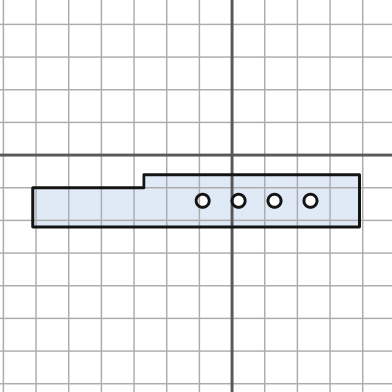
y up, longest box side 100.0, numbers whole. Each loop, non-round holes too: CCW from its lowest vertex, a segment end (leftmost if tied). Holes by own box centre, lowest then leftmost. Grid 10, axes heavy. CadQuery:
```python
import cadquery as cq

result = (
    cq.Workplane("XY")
    .moveTo(-61.0, -22.0)
    .lineTo(39.0, -22.0)
    .lineTo(39.0, -6.0)
    .lineTo(-27.0, -6.0)
    .lineTo(-27.0, -10.0)
    .lineTo(-61.0, -10.0)
    .close()
    .moveTo(-9.0, -14.0)
    .circle(2.0)
    .moveTo(2.0, -14.0)
    .circle(2.0)
    .moveTo(13.0, -14.0)
    .circle(2.0)
    .moveTo(24.0, -14.0)
    .circle(2.0)
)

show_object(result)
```